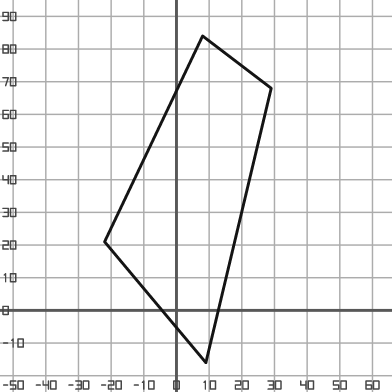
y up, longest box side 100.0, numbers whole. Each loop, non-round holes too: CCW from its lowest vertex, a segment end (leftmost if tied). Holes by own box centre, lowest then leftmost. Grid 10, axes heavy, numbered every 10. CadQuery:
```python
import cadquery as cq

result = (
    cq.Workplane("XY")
    .moveTo(9.0, -16.0)
    .lineTo(29.0, 68.0)
    .lineTo(8.0, 84.0)
    .lineTo(-22.0, 21.0)
    .close()
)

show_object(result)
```